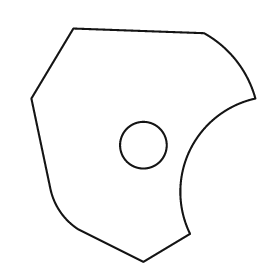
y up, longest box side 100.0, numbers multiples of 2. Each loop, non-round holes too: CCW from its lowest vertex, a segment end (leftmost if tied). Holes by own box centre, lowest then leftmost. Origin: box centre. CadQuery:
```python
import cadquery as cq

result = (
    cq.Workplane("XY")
    .moveTo(0.0, -50.0)
    .lineTo(20.0, -38.0)
    .threePointArc((20.0, -2.0), (48.0, 20.0))
    .threePointArc((40.0, 36.0), (26.0, 48.0))
    .lineTo(-30.0, 50.0)
    .lineTo(-48.0, 20.0)
    .lineTo(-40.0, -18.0)
    .threePointArc((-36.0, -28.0), (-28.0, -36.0))
    .close()
    .moveTo(0.0, 0.0)
    .circle(10.0)
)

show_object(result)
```